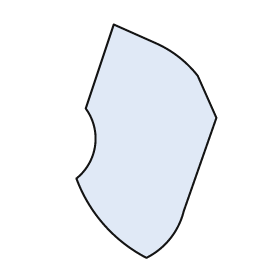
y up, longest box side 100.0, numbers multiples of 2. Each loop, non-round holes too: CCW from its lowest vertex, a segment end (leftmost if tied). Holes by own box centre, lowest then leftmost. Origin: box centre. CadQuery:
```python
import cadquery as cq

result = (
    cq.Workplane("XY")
    .moveTo(0.0, -50.0)
    .threePointArc((10.0, -42.0), (16.0, -30.0))
    .lineTo(30.0, 10.0)
    .lineTo(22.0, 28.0)
    .threePointArc((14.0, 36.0), (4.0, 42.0))
    .lineTo(-14.0, 50.0)
    .lineTo(-26.0, 14.0)
    .threePointArc((-22.0, -2.0), (-30.0, -16.0))
    .threePointArc((-18.0, -36.0), (0.0, -50.0))
    .close()
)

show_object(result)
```